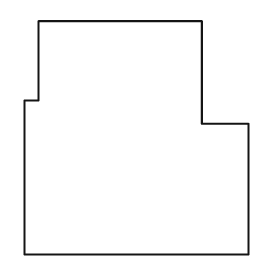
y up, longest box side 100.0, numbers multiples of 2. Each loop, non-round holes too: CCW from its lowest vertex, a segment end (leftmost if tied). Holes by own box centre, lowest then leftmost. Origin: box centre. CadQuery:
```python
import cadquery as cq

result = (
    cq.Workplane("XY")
    .moveTo(-48.0, -50.0)
    .lineTo(48.0, -50.0)
    .lineTo(48.0, 6.0)
    .lineTo(28.0, 6.0)
    .lineTo(28.0, 50.0)
    .lineTo(-42.0, 50.0)
    .lineTo(-42.0, 16.0)
    .lineTo(-48.0, 16.0)
    .close()
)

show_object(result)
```